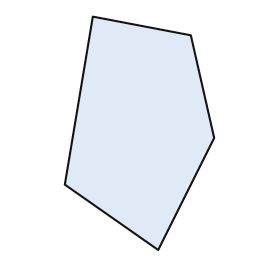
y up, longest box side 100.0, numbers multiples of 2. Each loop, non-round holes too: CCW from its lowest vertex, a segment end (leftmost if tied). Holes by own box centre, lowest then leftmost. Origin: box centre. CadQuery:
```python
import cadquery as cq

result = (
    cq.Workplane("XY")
    .moveTo(8.0, -50.0)
    .lineTo(32.0, -2.0)
    .lineTo(22.0, 42.0)
    .lineTo(-20.0, 50.0)
    .lineTo(-32.0, -22.0)
    .close()
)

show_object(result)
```